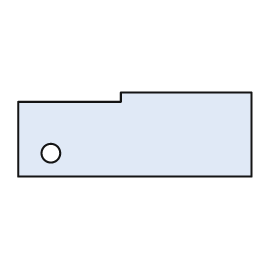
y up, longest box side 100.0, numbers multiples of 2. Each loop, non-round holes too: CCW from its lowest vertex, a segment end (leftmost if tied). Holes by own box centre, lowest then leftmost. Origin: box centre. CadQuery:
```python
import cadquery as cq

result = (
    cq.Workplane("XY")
    .moveTo(-50.0, -18.0)
    .lineTo(50.0, -18.0)
    .lineTo(50.0, 18.0)
    .lineTo(-6.0, 18.0)
    .lineTo(-6.0, 14.0)
    .lineTo(-50.0, 14.0)
    .close()
    .moveTo(-36.0, -8.0)
    .circle(4.0)
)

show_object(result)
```